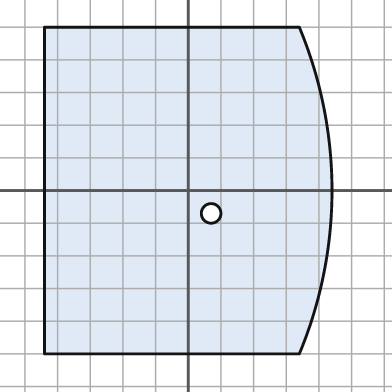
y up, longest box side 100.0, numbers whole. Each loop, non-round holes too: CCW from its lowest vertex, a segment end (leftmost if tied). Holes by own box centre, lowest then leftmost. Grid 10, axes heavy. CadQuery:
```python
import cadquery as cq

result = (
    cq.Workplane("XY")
    .moveTo(-44.0, -50.0)
    .lineTo(34.0, -50.0)
    .threePointArc((44.0, 0.0), (34.0, 50.0))
    .lineTo(-44.0, 50.0)
    .close()
    .moveTo(7.0, -7.0)
    .circle(3.0)
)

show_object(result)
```